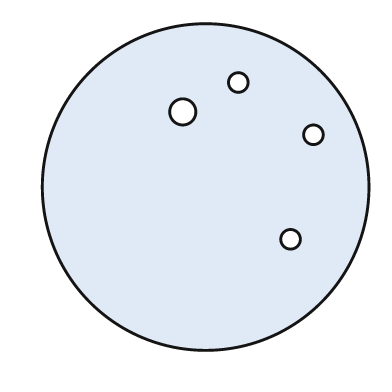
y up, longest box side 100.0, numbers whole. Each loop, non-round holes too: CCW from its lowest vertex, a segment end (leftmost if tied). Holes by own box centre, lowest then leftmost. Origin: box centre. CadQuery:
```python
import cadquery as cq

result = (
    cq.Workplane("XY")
    .moveTo(0.0, 0.0)
    .circle(50.0)
    .moveTo(26.0, -16.0)
    .circle(3.0)
    .moveTo(33.0, 16.0)
    .circle(3.0)
    .moveTo(-7.0, 23.0)
    .circle(4.0)
    .moveTo(10.0, 32.0)
    .circle(3.0)
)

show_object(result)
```